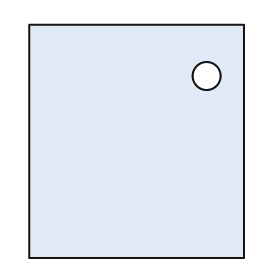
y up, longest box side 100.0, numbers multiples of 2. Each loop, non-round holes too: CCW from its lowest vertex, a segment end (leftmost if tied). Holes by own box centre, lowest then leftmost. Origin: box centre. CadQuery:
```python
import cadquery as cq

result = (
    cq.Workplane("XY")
    .moveTo(-46.0, -50.0)
    .lineTo(46.0, -50.0)
    .lineTo(46.0, 50.0)
    .lineTo(-46.0, 50.0)
    .close()
    .moveTo(30.0, 28.0)
    .circle(6.0)
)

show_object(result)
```